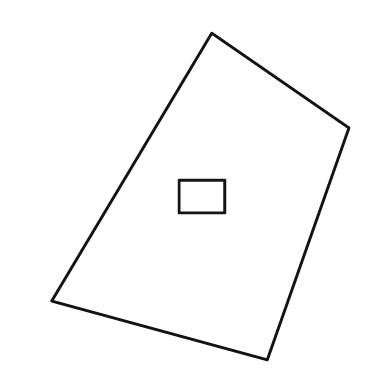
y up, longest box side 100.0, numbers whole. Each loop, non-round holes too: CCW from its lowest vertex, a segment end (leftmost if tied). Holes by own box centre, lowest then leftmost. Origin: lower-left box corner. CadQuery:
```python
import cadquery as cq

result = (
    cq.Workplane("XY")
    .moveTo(66.0, 0.0)
    .lineTo(91.0, 71.0)
    .lineTo(49.0, 100.0)
    .lineTo(0.0, 18.0)
    .close()
    .moveTo(39.0, 45.0)
    .lineTo(53.0, 45.0)
    .lineTo(53.0, 55.0)
    .lineTo(39.0, 55.0)
    .close()
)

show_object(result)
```